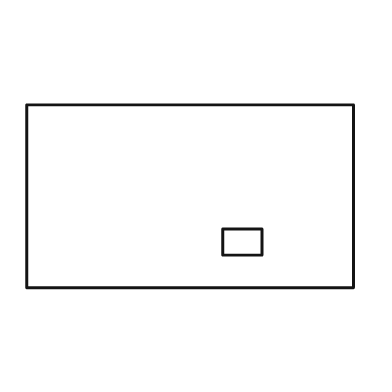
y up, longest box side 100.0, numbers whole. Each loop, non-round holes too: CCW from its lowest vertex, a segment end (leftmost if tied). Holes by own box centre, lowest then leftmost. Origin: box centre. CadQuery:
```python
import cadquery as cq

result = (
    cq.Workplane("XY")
    .moveTo(-50.0, -28.0)
    .lineTo(50.0, -28.0)
    .lineTo(50.0, 28.0)
    .lineTo(-50.0, 28.0)
    .close()
    .moveTo(10.0, -18.0)
    .lineTo(22.0, -18.0)
    .lineTo(22.0, -10.0)
    .lineTo(10.0, -10.0)
    .close()
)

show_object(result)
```